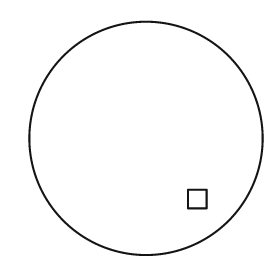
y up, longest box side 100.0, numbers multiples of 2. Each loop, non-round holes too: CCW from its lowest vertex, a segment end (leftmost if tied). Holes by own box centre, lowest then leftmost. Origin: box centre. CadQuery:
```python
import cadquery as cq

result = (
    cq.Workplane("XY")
    .moveTo(0.0, 0.0)
    .circle(50.0)
    .moveTo(18.0, -30.0)
    .lineTo(26.0, -30.0)
    .lineTo(26.0, -22.0)
    .lineTo(18.0, -22.0)
    .close()
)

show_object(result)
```